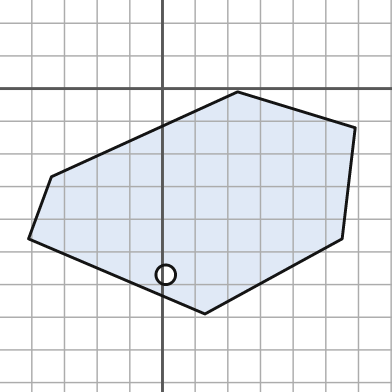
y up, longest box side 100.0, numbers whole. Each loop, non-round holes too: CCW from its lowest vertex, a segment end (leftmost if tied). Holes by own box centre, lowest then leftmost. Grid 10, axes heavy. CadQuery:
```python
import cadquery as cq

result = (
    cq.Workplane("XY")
    .moveTo(13.0, -69.0)
    .lineTo(55.0, -46.0)
    .lineTo(59.0, -12.0)
    .lineTo(23.0, -1.0)
    .lineTo(-34.0, -27.0)
    .lineTo(-41.0, -46.0)
    .close()
    .moveTo(1.0, -57.0)
    .circle(3.0)
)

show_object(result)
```